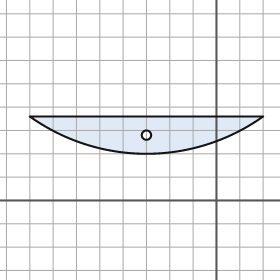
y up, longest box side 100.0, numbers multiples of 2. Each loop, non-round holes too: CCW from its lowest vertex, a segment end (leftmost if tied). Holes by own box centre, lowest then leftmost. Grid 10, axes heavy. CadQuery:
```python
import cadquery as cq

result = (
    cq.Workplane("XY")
    .moveTo(-80.0, 36.0)
    .threePointArc((-30.0, 20.0), (20.0, 36.0))
    .close()
    .moveTo(-30.0, 28.0)
    .circle(2.0)
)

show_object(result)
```